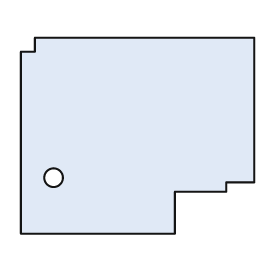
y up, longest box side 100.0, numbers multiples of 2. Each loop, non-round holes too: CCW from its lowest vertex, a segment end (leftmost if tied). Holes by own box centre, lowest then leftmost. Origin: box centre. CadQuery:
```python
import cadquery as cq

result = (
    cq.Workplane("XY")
    .moveTo(-50.0, -42.0)
    .lineTo(16.0, -42.0)
    .lineTo(16.0, -24.0)
    .lineTo(38.0, -24.0)
    .lineTo(38.0, -20.0)
    .lineTo(50.0, -20.0)
    .lineTo(50.0, 42.0)
    .lineTo(-44.0, 42.0)
    .lineTo(-44.0, 36.0)
    .lineTo(-50.0, 36.0)
    .close()
    .moveTo(-36.0, -18.0)
    .circle(4.0)
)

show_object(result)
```